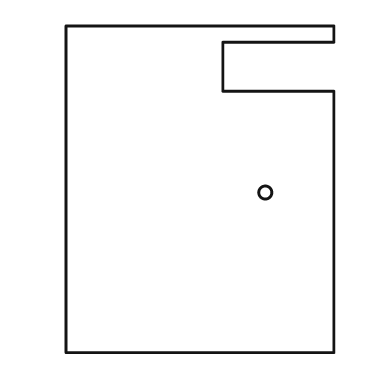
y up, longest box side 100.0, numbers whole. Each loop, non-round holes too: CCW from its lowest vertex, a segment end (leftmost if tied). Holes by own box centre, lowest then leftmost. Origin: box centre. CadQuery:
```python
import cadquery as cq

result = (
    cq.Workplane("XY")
    .moveTo(-41.0, -50.0)
    .lineTo(41.0, -50.0)
    .lineTo(41.0, 30.0)
    .lineTo(7.0, 30.0)
    .lineTo(7.0, 45.0)
    .lineTo(41.0, 45.0)
    .lineTo(41.0, 50.0)
    .lineTo(-41.0, 50.0)
    .close()
    .moveTo(20.0, -1.0)
    .circle(2.0)
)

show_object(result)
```